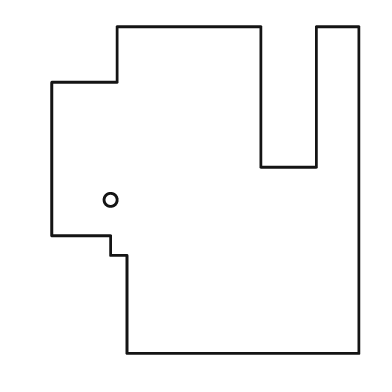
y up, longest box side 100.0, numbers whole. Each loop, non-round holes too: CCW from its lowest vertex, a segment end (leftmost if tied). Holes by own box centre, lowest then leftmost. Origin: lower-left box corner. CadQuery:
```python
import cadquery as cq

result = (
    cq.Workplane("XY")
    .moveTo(23.0, 0.0)
    .lineTo(94.0, 0.0)
    .lineTo(94.0, 100.0)
    .lineTo(81.0, 100.0)
    .lineTo(81.0, 57.0)
    .lineTo(64.0, 57.0)
    .lineTo(64.0, 100.0)
    .lineTo(20.0, 100.0)
    .lineTo(20.0, 83.0)
    .lineTo(0.0, 83.0)
    .lineTo(0.0, 36.0)
    .lineTo(18.0, 36.0)
    .lineTo(18.0, 30.0)
    .lineTo(23.0, 30.0)
    .close()
    .moveTo(18.0, 47.0)
    .circle(2.0)
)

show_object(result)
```